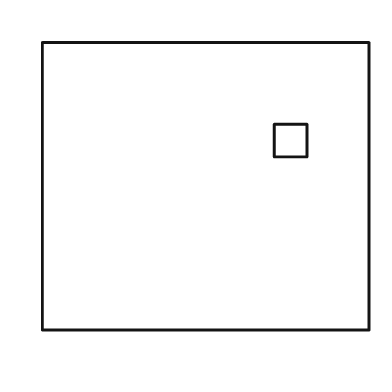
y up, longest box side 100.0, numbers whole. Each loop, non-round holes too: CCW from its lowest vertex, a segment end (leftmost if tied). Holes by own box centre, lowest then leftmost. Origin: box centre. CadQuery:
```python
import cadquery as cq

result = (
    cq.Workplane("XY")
    .moveTo(-50.0, -44.0)
    .lineTo(50.0, -44.0)
    .lineTo(50.0, 44.0)
    .lineTo(-50.0, 44.0)
    .close()
    .moveTo(21.0, 9.0)
    .lineTo(31.0, 9.0)
    .lineTo(31.0, 19.0)
    .lineTo(21.0, 19.0)
    .close()
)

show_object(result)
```